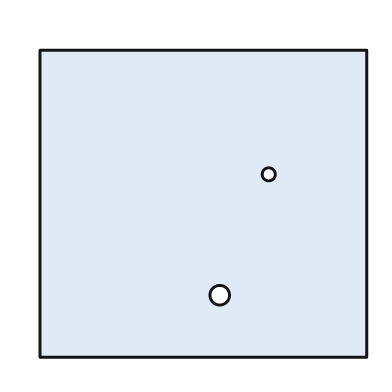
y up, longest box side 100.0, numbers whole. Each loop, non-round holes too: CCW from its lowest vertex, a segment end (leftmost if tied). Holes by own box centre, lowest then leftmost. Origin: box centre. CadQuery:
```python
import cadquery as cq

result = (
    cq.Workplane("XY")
    .moveTo(-50.0, -47.0)
    .lineTo(50.0, -47.0)
    .lineTo(50.0, 47.0)
    .lineTo(-50.0, 47.0)
    .close()
    .moveTo(5.0, -28.0)
    .circle(3.0)
    .moveTo(20.0, 9.0)
    .circle(2.0)
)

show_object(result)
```